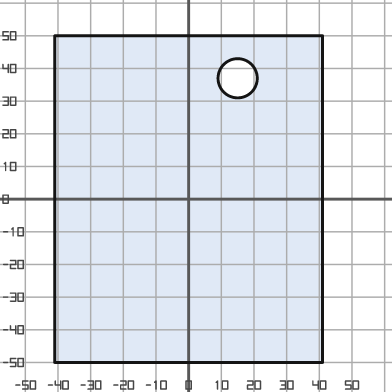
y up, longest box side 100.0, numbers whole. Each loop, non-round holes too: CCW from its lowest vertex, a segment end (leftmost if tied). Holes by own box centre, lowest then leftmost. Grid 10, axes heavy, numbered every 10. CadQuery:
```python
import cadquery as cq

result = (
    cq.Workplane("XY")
    .moveTo(-41.0, -50.0)
    .lineTo(41.0, -50.0)
    .lineTo(41.0, 50.0)
    .lineTo(-41.0, 50.0)
    .close()
    .moveTo(15.0, 37.0)
    .circle(6.0)
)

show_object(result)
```